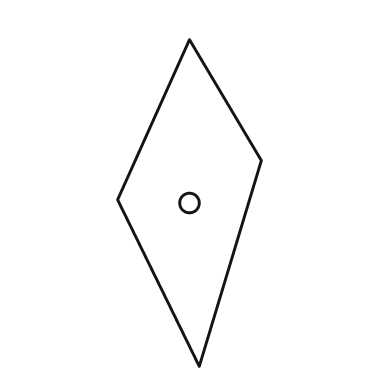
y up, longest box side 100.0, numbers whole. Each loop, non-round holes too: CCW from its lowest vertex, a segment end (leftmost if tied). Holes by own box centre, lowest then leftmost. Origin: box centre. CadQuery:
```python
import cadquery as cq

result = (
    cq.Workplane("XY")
    .moveTo(3.0, -50.0)
    .lineTo(22.0, 13.0)
    .lineTo(0.0, 50.0)
    .lineTo(-22.0, 1.0)
    .close()
    .moveTo(0.0, 0.0)
    .circle(3.0)
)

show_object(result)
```